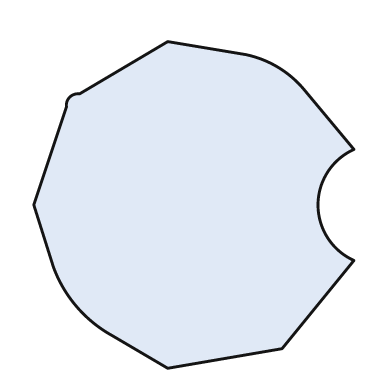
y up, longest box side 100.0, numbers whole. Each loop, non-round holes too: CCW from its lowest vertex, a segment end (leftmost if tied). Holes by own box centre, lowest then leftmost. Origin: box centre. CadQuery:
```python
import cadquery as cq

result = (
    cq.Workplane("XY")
    .moveTo(-8.0, -50.0)
    .lineTo(27.0, -44.0)
    .lineTo(49.0, -17.0)
    .threePointArc((38.0, 0.0), (49.0, 17.0))
    .lineTo(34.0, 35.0)
    .threePointArc((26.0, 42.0), (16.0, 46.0))
    .lineTo(-8.0, 50.0)
    .lineTo(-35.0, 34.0)
    .threePointArc((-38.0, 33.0), (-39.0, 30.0))
    .lineTo(-49.0, 0.0)
    .lineTo(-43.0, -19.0)
    .threePointArc((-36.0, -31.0), (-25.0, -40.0))
    .close()
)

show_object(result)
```